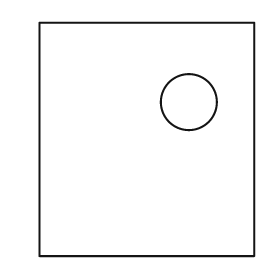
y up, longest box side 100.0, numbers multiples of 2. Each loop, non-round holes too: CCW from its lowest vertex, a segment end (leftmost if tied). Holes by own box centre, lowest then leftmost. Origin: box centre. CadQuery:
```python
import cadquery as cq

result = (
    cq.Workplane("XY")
    .moveTo(-46.0, -50.0)
    .lineTo(46.0, -50.0)
    .lineTo(46.0, 50.0)
    .lineTo(-46.0, 50.0)
    .close()
    .moveTo(18.0, 16.0)
    .circle(12.0)
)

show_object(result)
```